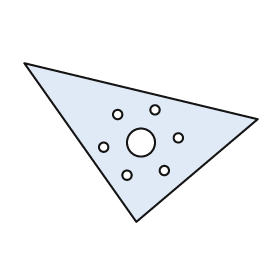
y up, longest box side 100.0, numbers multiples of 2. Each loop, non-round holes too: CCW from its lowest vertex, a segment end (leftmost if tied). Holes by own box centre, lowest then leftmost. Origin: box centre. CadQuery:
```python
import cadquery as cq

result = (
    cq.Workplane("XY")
    .moveTo(-2.0, -34.0)
    .lineTo(50.0, 10.0)
    .lineTo(-50.0, 34.0)
    .close()
    .moveTo(-6.0, -14.0)
    .circle(2.0)
    .moveTo(10.0, -12.0)
    .circle(2.0)
    .moveTo(-16.0, -2.0)
    .circle(2.0)
    .moveTo(0.0, 0.0)
    .circle(6.0)
    .moveTo(16.0, 2.0)
    .circle(2.0)
    .moveTo(-10.0, 12.0)
    .circle(2.0)
    .moveTo(6.0, 14.0)
    .circle(2.0)
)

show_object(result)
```